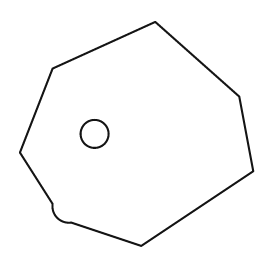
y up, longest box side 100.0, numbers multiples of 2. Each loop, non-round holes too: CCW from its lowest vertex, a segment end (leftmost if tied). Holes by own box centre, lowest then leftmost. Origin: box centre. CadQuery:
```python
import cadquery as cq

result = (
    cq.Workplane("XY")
    .moveTo(2.0, -48.0)
    .lineTo(50.0, -16.0)
    .lineTo(44.0, 16.0)
    .lineTo(8.0, 48.0)
    .lineTo(-36.0, 28.0)
    .lineTo(-50.0, -8.0)
    .lineTo(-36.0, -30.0)
    .threePointArc((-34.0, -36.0), (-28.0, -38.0))
    .close()
    .moveTo(-18.0, 0.0)
    .circle(6.0)
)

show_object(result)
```